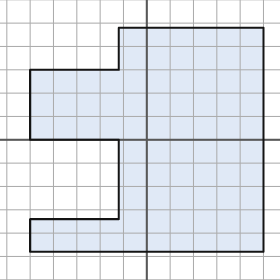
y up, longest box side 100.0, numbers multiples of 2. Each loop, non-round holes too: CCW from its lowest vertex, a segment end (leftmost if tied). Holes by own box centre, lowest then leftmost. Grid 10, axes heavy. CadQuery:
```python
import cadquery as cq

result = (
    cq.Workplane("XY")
    .moveTo(-50.0, -48.0)
    .lineTo(50.0, -48.0)
    .lineTo(50.0, 48.0)
    .lineTo(-12.0, 48.0)
    .lineTo(-12.0, 30.0)
    .lineTo(-50.0, 30.0)
    .lineTo(-50.0, 0.0)
    .lineTo(-12.0, 0.0)
    .lineTo(-12.0, -34.0)
    .lineTo(-50.0, -34.0)
    .close()
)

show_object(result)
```